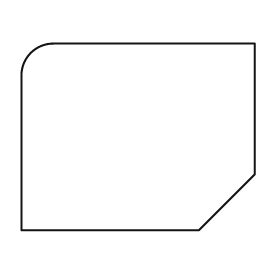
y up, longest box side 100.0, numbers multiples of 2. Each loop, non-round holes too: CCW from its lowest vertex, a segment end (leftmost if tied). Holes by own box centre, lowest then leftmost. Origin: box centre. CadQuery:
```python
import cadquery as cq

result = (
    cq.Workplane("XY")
    .moveTo(-50.0, -40.0)
    .lineTo(26.0, -40.0)
    .lineTo(50.0, -16.0)
    .lineTo(50.0, 40.0)
    .lineTo(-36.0, 40.0)
    .threePointArc((-46.0, 36.0), (-50.0, 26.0))
    .close()
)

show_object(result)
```